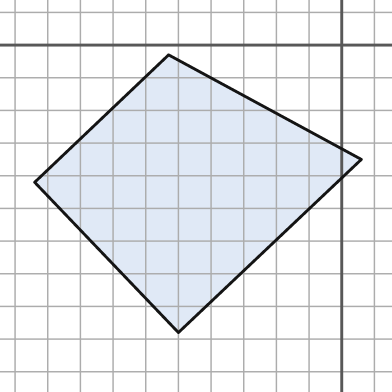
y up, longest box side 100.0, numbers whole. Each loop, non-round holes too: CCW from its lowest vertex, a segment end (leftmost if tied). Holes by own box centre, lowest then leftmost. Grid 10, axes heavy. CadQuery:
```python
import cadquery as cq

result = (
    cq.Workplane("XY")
    .moveTo(-50.0, -88.0)
    .lineTo(6.0, -35.0)
    .lineTo(-53.0, -3.0)
    .lineTo(-94.0, -42.0)
    .close()
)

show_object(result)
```